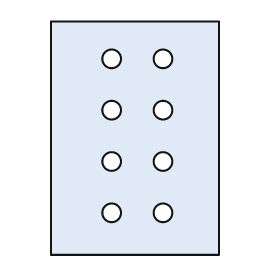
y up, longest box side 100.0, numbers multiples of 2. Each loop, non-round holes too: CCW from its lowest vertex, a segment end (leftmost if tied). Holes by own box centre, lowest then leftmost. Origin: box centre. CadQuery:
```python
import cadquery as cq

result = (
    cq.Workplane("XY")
    .moveTo(-36.0, -50.0)
    .lineTo(36.0, -50.0)
    .lineTo(36.0, 50.0)
    .lineTo(-36.0, 50.0)
    .close()
    .moveTo(-10.0, -32.0)
    .circle(4.0)
    .moveTo(12.0, -32.0)
    .circle(4.0)
    .moveTo(-10.0, -10.0)
    .circle(4.0)
    .moveTo(12.0, -10.0)
    .circle(4.0)
    .moveTo(-10.0, 12.0)
    .circle(4.0)
    .moveTo(12.0, 12.0)
    .circle(4.0)
    .moveTo(-10.0, 34.0)
    .circle(4.0)
    .moveTo(12.0, 34.0)
    .circle(4.0)
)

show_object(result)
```